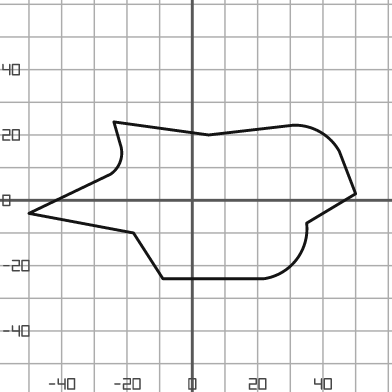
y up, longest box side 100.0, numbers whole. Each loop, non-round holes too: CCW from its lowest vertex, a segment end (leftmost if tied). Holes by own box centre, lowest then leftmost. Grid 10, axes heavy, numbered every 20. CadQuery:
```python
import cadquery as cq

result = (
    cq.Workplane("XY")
    .moveTo(-9.0, -24.0)
    .lineTo(22.0, -24.0)
    .threePointArc((32.0, -18.0), (35.0, -7.0))
    .lineTo(50.0, 2.0)
    .lineTo(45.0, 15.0)
    .threePointArc((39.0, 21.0), (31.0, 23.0))
    .lineTo(5.0, 20.0)
    .lineTo(-24.0, 24.0)
    .lineTo(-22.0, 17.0)
    .threePointArc((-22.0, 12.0), (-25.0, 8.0))
    .lineTo(-50.0, -4.0)
    .lineTo(-18.0, -10.0)
    .close()
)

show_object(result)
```